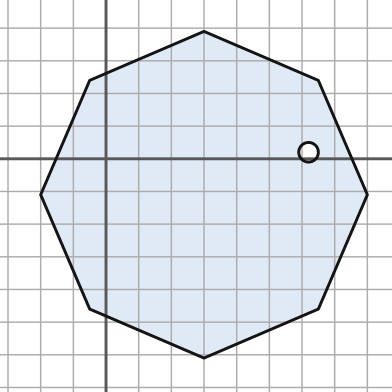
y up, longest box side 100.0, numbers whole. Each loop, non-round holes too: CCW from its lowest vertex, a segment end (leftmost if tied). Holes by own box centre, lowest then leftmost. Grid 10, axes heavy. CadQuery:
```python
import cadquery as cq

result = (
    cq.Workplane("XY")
    .moveTo(30.0, -61.0)
    .lineTo(65.0, -46.0)
    .lineTo(80.0, -11.0)
    .lineTo(65.0, 24.0)
    .lineTo(30.0, 39.0)
    .lineTo(-5.0, 24.0)
    .lineTo(-20.0, -11.0)
    .lineTo(-5.0, -46.0)
    .close()
    .moveTo(62.0, 2.0)
    .circle(3.0)
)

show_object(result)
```